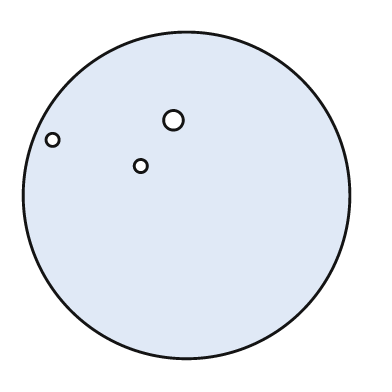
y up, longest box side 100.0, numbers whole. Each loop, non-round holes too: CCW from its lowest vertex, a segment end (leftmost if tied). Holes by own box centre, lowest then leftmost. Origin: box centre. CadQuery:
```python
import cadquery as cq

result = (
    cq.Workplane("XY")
    .moveTo(0.0, 0.0)
    .circle(50.0)
    .moveTo(-14.0, 9.0)
    .circle(2.0)
    .moveTo(-41.0, 17.0)
    .circle(2.0)
    .moveTo(-4.0, 23.0)
    .circle(3.0)
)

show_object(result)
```